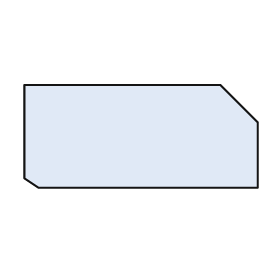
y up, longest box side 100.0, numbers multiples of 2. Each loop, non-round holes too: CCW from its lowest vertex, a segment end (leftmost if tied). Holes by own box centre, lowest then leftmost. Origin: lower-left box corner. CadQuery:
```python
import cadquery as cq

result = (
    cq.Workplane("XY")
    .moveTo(6.0, 0.0)
    .lineTo(100.0, 0.0)
    .lineTo(100.0, 28.0)
    .lineTo(84.0, 44.0)
    .lineTo(0.0, 44.0)
    .lineTo(0.0, 4.0)
    .close()
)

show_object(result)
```